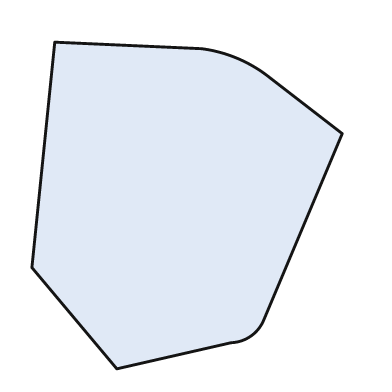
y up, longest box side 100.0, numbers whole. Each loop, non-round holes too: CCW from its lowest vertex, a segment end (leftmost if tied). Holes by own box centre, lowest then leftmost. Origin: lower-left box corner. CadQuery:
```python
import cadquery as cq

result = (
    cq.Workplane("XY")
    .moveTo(26.0, 0.0)
    .lineTo(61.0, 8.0)
    .threePointArc((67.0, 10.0), (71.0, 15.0))
    .lineTo(95.0, 72.0)
    .lineTo(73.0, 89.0)
    .threePointArc((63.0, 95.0), (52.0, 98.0))
    .lineTo(7.0, 100.0)
    .lineTo(0.0, 31.0)
    .close()
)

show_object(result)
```